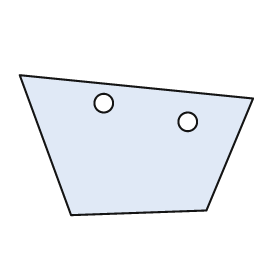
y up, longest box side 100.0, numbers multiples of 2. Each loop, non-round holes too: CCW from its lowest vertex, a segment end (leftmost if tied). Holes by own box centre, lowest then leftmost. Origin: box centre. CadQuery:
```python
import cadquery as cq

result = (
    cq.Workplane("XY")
    .moveTo(-28.0, -30.0)
    .lineTo(30.0, -28.0)
    .lineTo(50.0, 20.0)
    .lineTo(-50.0, 30.0)
    .close()
    .moveTo(22.0, 10.0)
    .circle(4.0)
    .moveTo(-14.0, 18.0)
    .circle(4.0)
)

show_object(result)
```